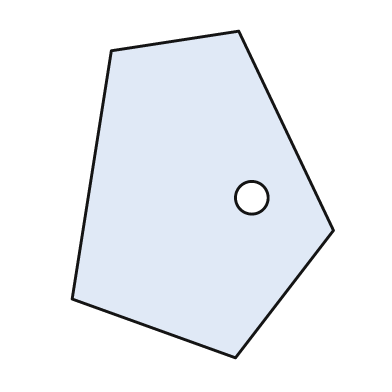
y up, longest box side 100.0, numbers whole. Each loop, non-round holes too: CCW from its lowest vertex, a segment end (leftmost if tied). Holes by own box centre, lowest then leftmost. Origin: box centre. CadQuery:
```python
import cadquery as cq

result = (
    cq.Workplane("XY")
    .moveTo(10.0, -50.0)
    .lineTo(40.0, -11.0)
    .lineTo(11.0, 50.0)
    .lineTo(-28.0, 44.0)
    .lineTo(-40.0, -32.0)
    .close()
    .moveTo(15.0, -1.0)
    .circle(5.0)
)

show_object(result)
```